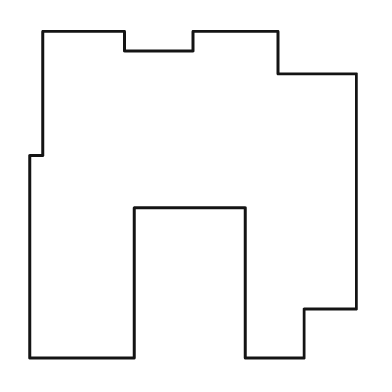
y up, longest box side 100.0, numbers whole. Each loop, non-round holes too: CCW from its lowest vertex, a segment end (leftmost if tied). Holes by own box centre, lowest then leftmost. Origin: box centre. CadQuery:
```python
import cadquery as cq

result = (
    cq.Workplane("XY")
    .moveTo(-50.0, -50.0)
    .lineTo(-18.0, -50.0)
    .lineTo(-18.0, -4.0)
    .lineTo(16.0, -4.0)
    .lineTo(16.0, -50.0)
    .lineTo(34.0, -50.0)
    .lineTo(34.0, -35.0)
    .lineTo(50.0, -35.0)
    .lineTo(50.0, 37.0)
    .lineTo(26.0, 37.0)
    .lineTo(26.0, 50.0)
    .lineTo(0.0, 50.0)
    .lineTo(0.0, 44.0)
    .lineTo(-21.0, 44.0)
    .lineTo(-21.0, 50.0)
    .lineTo(-46.0, 50.0)
    .lineTo(-46.0, 12.0)
    .lineTo(-50.0, 12.0)
    .close()
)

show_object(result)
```